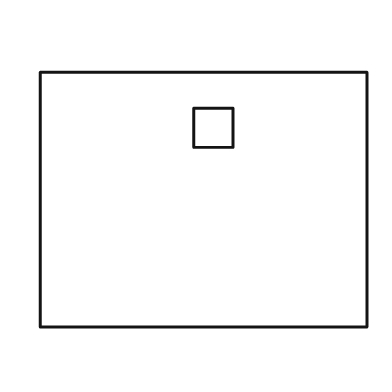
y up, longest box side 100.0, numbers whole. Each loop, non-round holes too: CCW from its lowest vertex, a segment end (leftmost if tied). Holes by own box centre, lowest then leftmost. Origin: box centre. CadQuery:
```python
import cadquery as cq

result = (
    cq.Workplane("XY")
    .moveTo(-50.0, -39.0)
    .lineTo(50.0, -39.0)
    .lineTo(50.0, 39.0)
    .lineTo(-50.0, 39.0)
    .close()
    .moveTo(-3.0, 16.0)
    .lineTo(9.0, 16.0)
    .lineTo(9.0, 28.0)
    .lineTo(-3.0, 28.0)
    .close()
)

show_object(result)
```